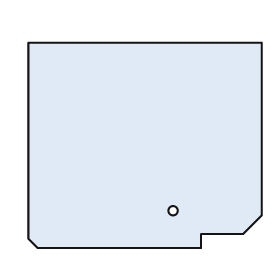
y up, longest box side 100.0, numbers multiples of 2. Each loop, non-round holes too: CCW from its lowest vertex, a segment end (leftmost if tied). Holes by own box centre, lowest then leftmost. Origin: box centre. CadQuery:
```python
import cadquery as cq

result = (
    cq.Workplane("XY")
    .moveTo(-46.0, -44.0)
    .lineTo(24.0, -44.0)
    .lineTo(24.0, -38.0)
    .lineTo(42.0, -38.0)
    .lineTo(50.0, -30.0)
    .lineTo(50.0, 44.0)
    .lineTo(-50.0, 44.0)
    .lineTo(-50.0, -40.0)
    .close()
    .moveTo(12.0, -28.0)
    .circle(2.0)
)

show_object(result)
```